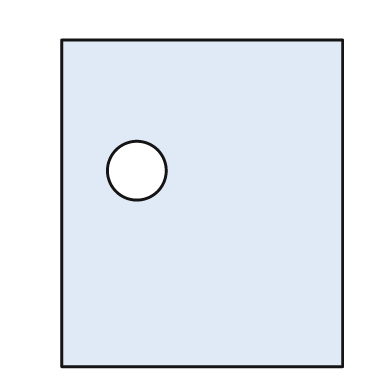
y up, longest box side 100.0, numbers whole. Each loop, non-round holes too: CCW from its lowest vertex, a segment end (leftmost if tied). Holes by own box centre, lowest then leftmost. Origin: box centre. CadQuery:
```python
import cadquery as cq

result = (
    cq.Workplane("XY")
    .moveTo(-43.0, -50.0)
    .lineTo(43.0, -50.0)
    .lineTo(43.0, 50.0)
    .lineTo(-43.0, 50.0)
    .close()
    .moveTo(-20.0, 10.0)
    .circle(9.0)
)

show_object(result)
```